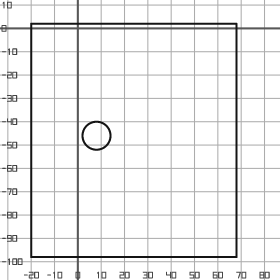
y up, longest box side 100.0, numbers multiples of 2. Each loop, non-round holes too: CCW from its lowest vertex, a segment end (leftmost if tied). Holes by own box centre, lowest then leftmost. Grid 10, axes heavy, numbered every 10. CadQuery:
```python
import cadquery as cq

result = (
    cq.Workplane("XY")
    .moveTo(-20.0, -98.0)
    .lineTo(68.0, -98.0)
    .lineTo(68.0, 2.0)
    .lineTo(-20.0, 2.0)
    .close()
    .moveTo(8.0, -46.0)
    .circle(6.0)
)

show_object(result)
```